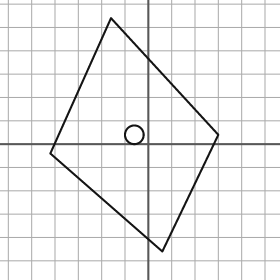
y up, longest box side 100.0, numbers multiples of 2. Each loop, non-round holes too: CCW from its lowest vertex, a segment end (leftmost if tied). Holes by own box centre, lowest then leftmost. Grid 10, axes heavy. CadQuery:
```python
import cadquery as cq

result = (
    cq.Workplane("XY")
    .moveTo(6.0, -46.0)
    .lineTo(30.0, 4.0)
    .lineTo(-16.0, 54.0)
    .lineTo(-42.0, -4.0)
    .close()
    .moveTo(-6.0, 4.0)
    .circle(4.0)
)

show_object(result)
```